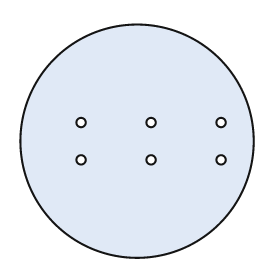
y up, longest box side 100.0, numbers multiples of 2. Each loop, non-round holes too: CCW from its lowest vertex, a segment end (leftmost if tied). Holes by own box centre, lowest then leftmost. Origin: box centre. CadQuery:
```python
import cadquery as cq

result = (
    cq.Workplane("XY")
    .moveTo(0.0, 0.0)
    .circle(50.0)
    .moveTo(-24.0, -8.0)
    .circle(2.0)
    .moveTo(6.0, -8.0)
    .circle(2.0)
    .moveTo(36.0, -8.0)
    .circle(2.0)
    .moveTo(-24.0, 8.0)
    .circle(2.0)
    .moveTo(6.0, 8.0)
    .circle(2.0)
    .moveTo(36.0, 8.0)
    .circle(2.0)
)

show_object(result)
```